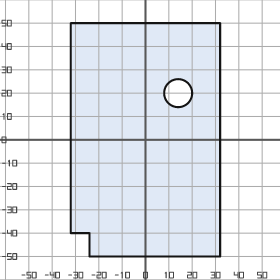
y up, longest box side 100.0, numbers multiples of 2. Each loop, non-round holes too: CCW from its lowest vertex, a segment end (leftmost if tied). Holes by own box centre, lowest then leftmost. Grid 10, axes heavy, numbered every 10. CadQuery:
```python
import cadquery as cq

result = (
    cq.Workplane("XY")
    .moveTo(-24.0, -50.0)
    .lineTo(32.0, -50.0)
    .lineTo(32.0, 50.0)
    .lineTo(-32.0, 50.0)
    .lineTo(-32.0, -40.0)
    .lineTo(-24.0, -40.0)
    .close()
    .moveTo(14.0, 20.0)
    .circle(6.0)
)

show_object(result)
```